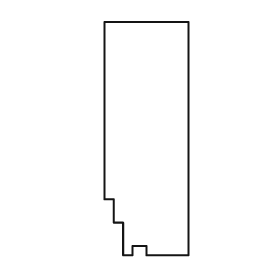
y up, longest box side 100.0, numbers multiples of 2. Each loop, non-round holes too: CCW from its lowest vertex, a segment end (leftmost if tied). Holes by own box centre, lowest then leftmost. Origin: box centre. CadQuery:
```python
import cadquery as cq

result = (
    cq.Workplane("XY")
    .moveTo(-10.0, -50.0)
    .lineTo(-6.0, -50.0)
    .lineTo(-6.0, -46.0)
    .lineTo(0.0, -46.0)
    .lineTo(0.0, -50.0)
    .lineTo(18.0, -50.0)
    .lineTo(18.0, 50.0)
    .lineTo(-18.0, 50.0)
    .lineTo(-18.0, -26.0)
    .lineTo(-14.0, -26.0)
    .lineTo(-14.0, -36.0)
    .lineTo(-10.0, -36.0)
    .close()
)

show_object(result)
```